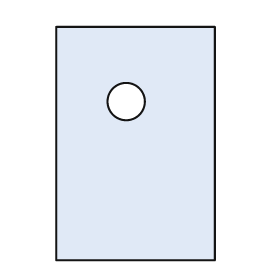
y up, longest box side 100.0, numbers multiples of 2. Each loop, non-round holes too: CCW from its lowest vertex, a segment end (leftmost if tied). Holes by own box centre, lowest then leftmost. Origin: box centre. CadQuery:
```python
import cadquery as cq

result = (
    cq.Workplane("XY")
    .moveTo(-34.0, -50.0)
    .lineTo(34.0, -50.0)
    .lineTo(34.0, 50.0)
    .lineTo(-34.0, 50.0)
    .close()
    .moveTo(-4.0, 18.0)
    .circle(8.0)
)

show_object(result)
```